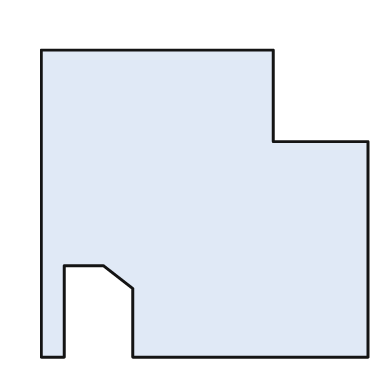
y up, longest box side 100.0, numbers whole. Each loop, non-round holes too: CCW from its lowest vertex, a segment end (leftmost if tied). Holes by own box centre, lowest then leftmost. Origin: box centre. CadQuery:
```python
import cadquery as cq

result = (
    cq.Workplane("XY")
    .moveTo(-50.0, -47.0)
    .lineTo(-43.0, -47.0)
    .lineTo(-43.0, -19.0)
    .lineTo(-31.0, -19.0)
    .lineTo(-22.0, -26.0)
    .lineTo(-22.0, -47.0)
    .lineTo(50.0, -47.0)
    .lineTo(50.0, 19.0)
    .lineTo(21.0, 19.0)
    .lineTo(21.0, 47.0)
    .lineTo(-50.0, 47.0)
    .close()
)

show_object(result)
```